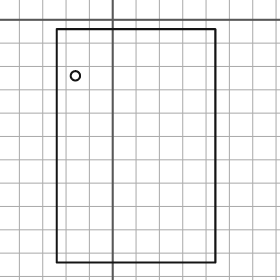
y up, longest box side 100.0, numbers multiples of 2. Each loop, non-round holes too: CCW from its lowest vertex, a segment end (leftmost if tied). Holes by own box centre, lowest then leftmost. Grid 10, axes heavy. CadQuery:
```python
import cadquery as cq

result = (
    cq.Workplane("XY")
    .moveTo(-24.0, -104.0)
    .lineTo(44.0, -104.0)
    .lineTo(44.0, -4.0)
    .lineTo(-24.0, -4.0)
    .close()
    .moveTo(-16.0, -24.0)
    .circle(2.0)
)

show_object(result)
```